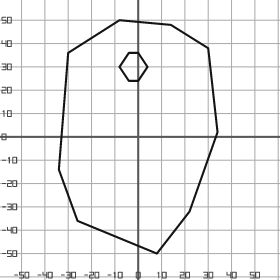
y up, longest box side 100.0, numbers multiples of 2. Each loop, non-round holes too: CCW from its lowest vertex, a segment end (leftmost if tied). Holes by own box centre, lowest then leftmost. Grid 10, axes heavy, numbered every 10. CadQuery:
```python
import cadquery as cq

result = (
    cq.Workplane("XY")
    .moveTo(8.0, -50.0)
    .lineTo(22.0, -32.0)
    .lineTo(34.0, 2.0)
    .lineTo(30.0, 38.0)
    .lineTo(14.0, 48.0)
    .lineTo(-8.0, 50.0)
    .lineTo(-30.0, 36.0)
    .lineTo(-34.0, -14.0)
    .lineTo(-26.0, -36.0)
    .close()
    .moveTo(-4.0, 24.0)
    .lineTo(0.0, 24.0)
    .lineTo(4.0, 30.0)
    .lineTo(0.0, 36.0)
    .lineTo(-4.0, 36.0)
    .lineTo(-8.0, 30.0)
    .close()
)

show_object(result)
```